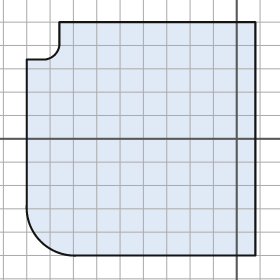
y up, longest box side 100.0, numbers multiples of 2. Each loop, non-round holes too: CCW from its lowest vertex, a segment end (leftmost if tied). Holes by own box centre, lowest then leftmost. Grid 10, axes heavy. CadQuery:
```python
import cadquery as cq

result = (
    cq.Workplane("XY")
    .moveTo(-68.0, -50.0)
    .lineTo(8.0, -50.0)
    .lineTo(8.0, 50.0)
    .lineTo(-76.0, 50.0)
    .lineTo(-76.0, 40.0)
    .threePointArc((-78.0, 36.0), (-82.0, 34.0))
    .lineTo(-90.0, 34.0)
    .lineTo(-90.0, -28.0)
    .threePointArc((-84.0, -44.0), (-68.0, -50.0))
    .close()
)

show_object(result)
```